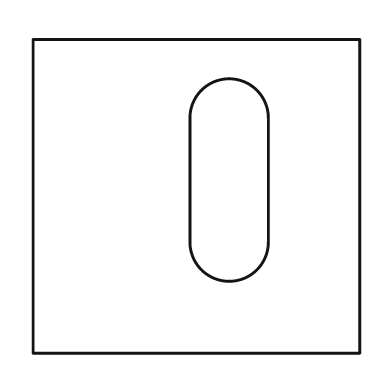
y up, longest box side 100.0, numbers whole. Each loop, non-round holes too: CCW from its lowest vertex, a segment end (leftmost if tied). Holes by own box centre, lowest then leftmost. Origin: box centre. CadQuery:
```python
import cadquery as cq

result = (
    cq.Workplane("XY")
    .moveTo(-50.0, -48.0)
    .lineTo(50.0, -48.0)
    .lineTo(50.0, 48.0)
    .lineTo(-50.0, 48.0)
    .close()
    .moveTo(-2.0, -14.0)
    .threePointArc((10.0, -26.0), (22.0, -14.0))
    .lineTo(22.0, 24.0)
    .threePointArc((10.0, 36.0), (-2.0, 24.0))
    .close()
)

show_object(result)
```